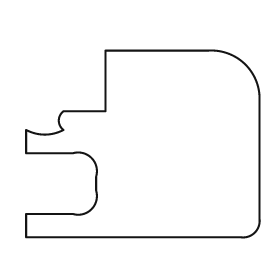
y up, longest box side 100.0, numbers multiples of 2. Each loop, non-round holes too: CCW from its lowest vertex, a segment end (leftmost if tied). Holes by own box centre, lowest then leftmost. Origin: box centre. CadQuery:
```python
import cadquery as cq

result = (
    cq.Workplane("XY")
    .moveTo(-50.0, -40.0)
    .lineTo(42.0, -40.0)
    .threePointArc((48.0, -38.0), (50.0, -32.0))
    .lineTo(50.0, 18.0)
    .threePointArc((44.0, 34.0), (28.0, 40.0))
    .lineTo(-16.0, 40.0)
    .lineTo(-16.0, 14.0)
    .lineTo(-34.0, 14.0)
    .threePointArc((-36.0, 10.0), (-34.0, 6.0))
    .threePointArc((-42.0, 4.0), (-50.0, 6.0))
    .lineTo(-50.0, -4.0)
    .lineTo(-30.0, -4.0)
    .threePointArc((-22.0, -6.0), (-20.0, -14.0))
    .lineTo(-20.0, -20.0)
    .threePointArc((-22.0, -28.0), (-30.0, -30.0))
    .lineTo(-50.0, -30.0)
    .close()
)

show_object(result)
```